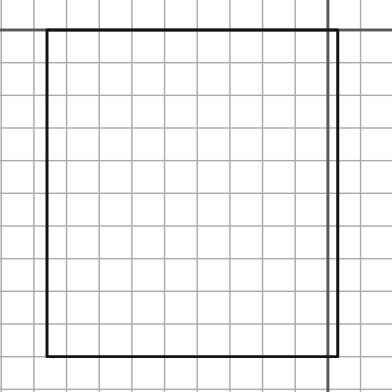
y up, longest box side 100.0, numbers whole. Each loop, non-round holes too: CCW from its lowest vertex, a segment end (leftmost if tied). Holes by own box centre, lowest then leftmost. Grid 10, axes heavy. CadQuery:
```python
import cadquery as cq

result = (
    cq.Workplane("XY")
    .moveTo(-86.0, -100.0)
    .lineTo(3.0, -100.0)
    .lineTo(3.0, 0.0)
    .lineTo(-86.0, 0.0)
    .close()
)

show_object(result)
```